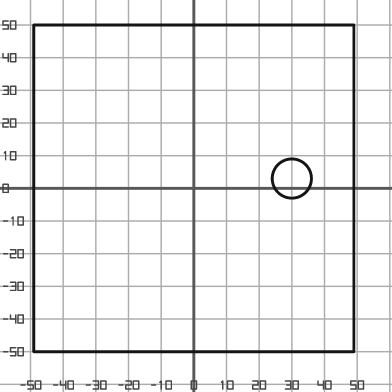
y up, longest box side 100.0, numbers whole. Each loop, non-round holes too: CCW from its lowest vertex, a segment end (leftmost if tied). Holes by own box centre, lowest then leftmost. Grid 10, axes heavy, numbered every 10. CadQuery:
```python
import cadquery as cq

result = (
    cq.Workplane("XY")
    .moveTo(-49.0, -50.0)
    .lineTo(49.0, -50.0)
    .lineTo(49.0, 50.0)
    .lineTo(-49.0, 50.0)
    .close()
    .moveTo(30.0, 3.0)
    .circle(6.0)
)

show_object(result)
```